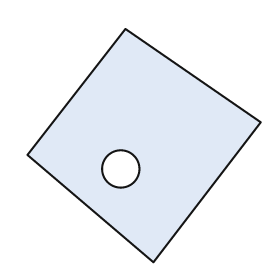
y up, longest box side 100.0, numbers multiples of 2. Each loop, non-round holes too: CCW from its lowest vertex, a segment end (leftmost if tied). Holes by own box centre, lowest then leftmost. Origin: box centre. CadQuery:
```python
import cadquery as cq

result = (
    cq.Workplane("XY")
    .moveTo(4.0, -50.0)
    .lineTo(50.0, 10.0)
    .lineTo(-8.0, 50.0)
    .lineTo(-50.0, -4.0)
    .close()
    .moveTo(-10.0, -10.0)
    .circle(8.0)
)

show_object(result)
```